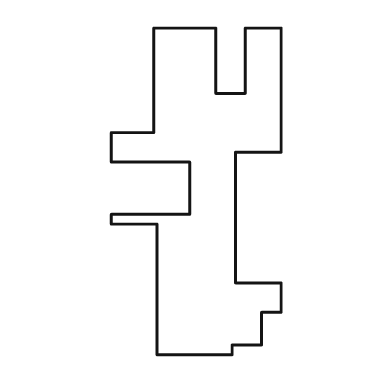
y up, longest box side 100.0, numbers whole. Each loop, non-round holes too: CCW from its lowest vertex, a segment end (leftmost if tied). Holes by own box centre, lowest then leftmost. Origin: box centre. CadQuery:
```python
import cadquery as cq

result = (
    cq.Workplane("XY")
    .moveTo(-12.0, -50.0)
    .lineTo(11.0, -50.0)
    .lineTo(11.0, -47.0)
    .lineTo(20.0, -47.0)
    .lineTo(20.0, -37.0)
    .lineTo(26.0, -37.0)
    .lineTo(26.0, -28.0)
    .lineTo(12.0, -28.0)
    .lineTo(12.0, 12.0)
    .lineTo(26.0, 12.0)
    .lineTo(26.0, 50.0)
    .lineTo(15.0, 50.0)
    .lineTo(15.0, 30.0)
    .lineTo(6.0, 30.0)
    .lineTo(6.0, 50.0)
    .lineTo(-13.0, 50.0)
    .lineTo(-13.0, 18.0)
    .lineTo(-26.0, 18.0)
    .lineTo(-26.0, 9.0)
    .lineTo(-2.0, 9.0)
    .lineTo(-2.0, -7.0)
    .lineTo(-26.0, -7.0)
    .lineTo(-26.0, -10.0)
    .lineTo(-12.0, -10.0)
    .close()
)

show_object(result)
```